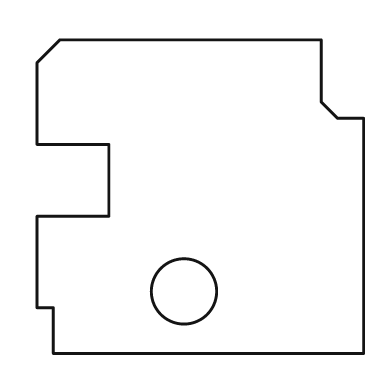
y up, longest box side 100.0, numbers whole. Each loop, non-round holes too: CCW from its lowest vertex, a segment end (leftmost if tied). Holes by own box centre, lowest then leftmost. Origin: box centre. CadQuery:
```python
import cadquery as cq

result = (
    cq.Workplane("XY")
    .moveTo(-45.0, -48.0)
    .lineTo(50.0, -48.0)
    .lineTo(50.0, 24.0)
    .lineTo(42.0, 24.0)
    .lineTo(37.0, 29.0)
    .lineTo(37.0, 48.0)
    .lineTo(-43.0, 48.0)
    .lineTo(-50.0, 41.0)
    .lineTo(-50.0, 16.0)
    .lineTo(-28.0, 16.0)
    .lineTo(-28.0, -6.0)
    .lineTo(-50.0, -6.0)
    .lineTo(-50.0, -34.0)
    .lineTo(-45.0, -34.0)
    .close()
    .moveTo(-5.0, -29.0)
    .circle(10.0)
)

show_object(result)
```